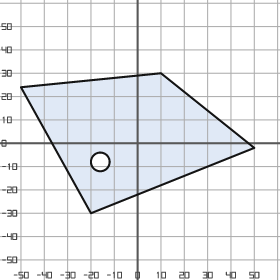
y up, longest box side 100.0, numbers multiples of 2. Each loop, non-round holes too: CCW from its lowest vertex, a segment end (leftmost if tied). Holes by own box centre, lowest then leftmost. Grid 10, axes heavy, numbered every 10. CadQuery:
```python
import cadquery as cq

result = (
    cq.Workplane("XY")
    .moveTo(-20.0, -30.0)
    .lineTo(50.0, -2.0)
    .lineTo(10.0, 30.0)
    .lineTo(-50.0, 24.0)
    .close()
    .moveTo(-16.0, -8.0)
    .circle(4.0)
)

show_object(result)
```